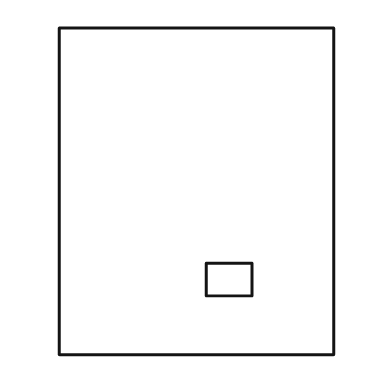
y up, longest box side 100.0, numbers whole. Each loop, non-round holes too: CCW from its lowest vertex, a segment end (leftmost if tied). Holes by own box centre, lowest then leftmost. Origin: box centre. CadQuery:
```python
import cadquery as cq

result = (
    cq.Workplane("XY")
    .moveTo(-42.0, -50.0)
    .lineTo(42.0, -50.0)
    .lineTo(42.0, 50.0)
    .lineTo(-42.0, 50.0)
    .close()
    .moveTo(3.0, -32.0)
    .lineTo(17.0, -32.0)
    .lineTo(17.0, -22.0)
    .lineTo(3.0, -22.0)
    .close()
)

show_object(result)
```